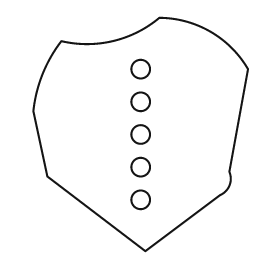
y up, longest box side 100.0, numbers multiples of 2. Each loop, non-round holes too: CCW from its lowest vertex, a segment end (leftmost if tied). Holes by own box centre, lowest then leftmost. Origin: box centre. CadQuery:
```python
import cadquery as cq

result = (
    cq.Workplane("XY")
    .moveTo(2.0, -50.0)
    .lineTo(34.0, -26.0)
    .threePointArc((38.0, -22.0), (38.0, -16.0))
    .lineTo(46.0, 28.0)
    .threePointArc((30.0, 44.0), (8.0, 50.0))
    .threePointArc((-12.0, 40.0), (-34.0, 40.0))
    .threePointArc((-42.0, 26.0), (-46.0, 10.0))
    .lineTo(-40.0, -18.0)
    .close()
    .moveTo(0.0, -28.0)
    .circle(4.0)
    .moveTo(0.0, -14.0)
    .circle(4.0)
    .moveTo(0.0, 0.0)
    .circle(4.0)
    .moveTo(0.0, 14.0)
    .circle(4.0)
    .moveTo(0.0, 28.0)
    .circle(4.0)
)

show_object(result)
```